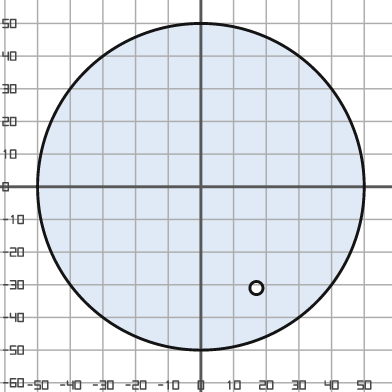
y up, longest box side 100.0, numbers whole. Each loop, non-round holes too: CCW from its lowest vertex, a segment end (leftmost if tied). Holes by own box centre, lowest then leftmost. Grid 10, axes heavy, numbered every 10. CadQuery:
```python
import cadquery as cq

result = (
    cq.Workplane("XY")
    .moveTo(0.0, 0.0)
    .circle(50.0)
    .moveTo(17.0, -31.0)
    .circle(2.0)
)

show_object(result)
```